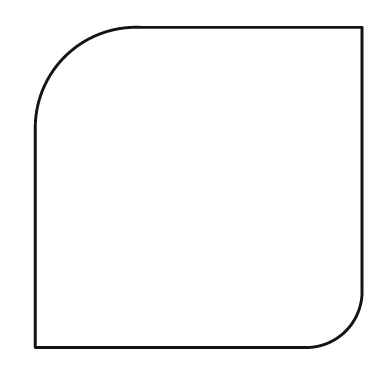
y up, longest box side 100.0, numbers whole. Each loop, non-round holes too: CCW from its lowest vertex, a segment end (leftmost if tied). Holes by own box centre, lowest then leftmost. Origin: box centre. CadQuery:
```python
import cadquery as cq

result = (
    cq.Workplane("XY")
    .moveTo(-50.0, -49.0)
    .lineTo(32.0, -49.0)
    .threePointArc((45.0, -44.0), (50.0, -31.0))
    .lineTo(50.0, 49.0)
    .lineTo(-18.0, 49.0)
    .threePointArc((-41.0, 40.0), (-50.0, 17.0))
    .close()
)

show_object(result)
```